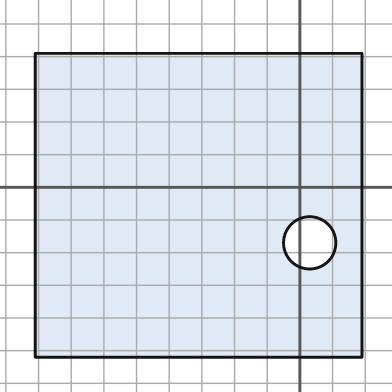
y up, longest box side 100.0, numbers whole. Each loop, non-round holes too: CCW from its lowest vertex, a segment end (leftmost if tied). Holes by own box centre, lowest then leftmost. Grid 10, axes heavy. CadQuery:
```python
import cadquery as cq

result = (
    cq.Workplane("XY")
    .moveTo(-81.0, -52.0)
    .lineTo(19.0, -52.0)
    .lineTo(19.0, 41.0)
    .lineTo(-81.0, 41.0)
    .close()
    .moveTo(3.0, -17.0)
    .circle(8.0)
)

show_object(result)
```